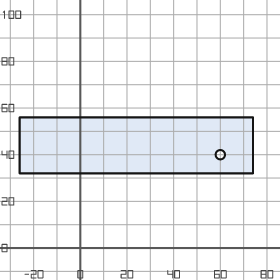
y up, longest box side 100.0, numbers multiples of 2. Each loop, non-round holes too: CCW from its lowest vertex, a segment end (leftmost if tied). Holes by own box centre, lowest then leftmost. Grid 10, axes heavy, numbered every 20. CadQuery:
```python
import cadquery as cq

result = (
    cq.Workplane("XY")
    .moveTo(-26.0, 32.0)
    .lineTo(74.0, 32.0)
    .lineTo(74.0, 56.0)
    .lineTo(-26.0, 56.0)
    .close()
    .moveTo(60.0, 40.0)
    .circle(2.0)
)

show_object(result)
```